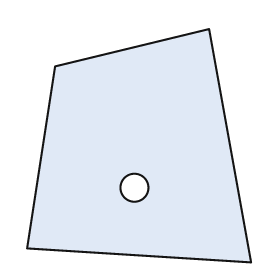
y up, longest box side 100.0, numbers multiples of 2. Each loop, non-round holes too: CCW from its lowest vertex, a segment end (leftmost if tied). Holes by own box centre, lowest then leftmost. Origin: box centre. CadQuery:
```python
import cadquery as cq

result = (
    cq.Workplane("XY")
    .moveTo(48.0, -50.0)
    .lineTo(30.0, 50.0)
    .lineTo(-36.0, 34.0)
    .lineTo(-48.0, -44.0)
    .close()
    .moveTo(-2.0, -18.0)
    .circle(6.0)
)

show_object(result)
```